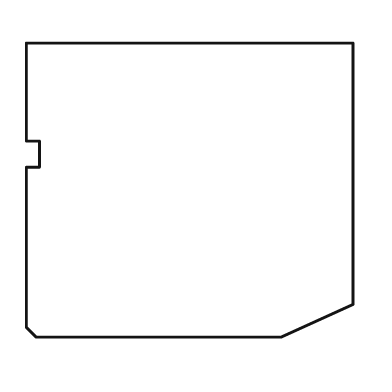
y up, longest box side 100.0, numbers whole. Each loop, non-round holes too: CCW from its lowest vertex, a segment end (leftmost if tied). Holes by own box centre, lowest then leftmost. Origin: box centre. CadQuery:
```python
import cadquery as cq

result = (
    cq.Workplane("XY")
    .moveTo(-47.0, -45.0)
    .lineTo(28.0, -45.0)
    .lineTo(50.0, -35.0)
    .lineTo(50.0, 45.0)
    .lineTo(-50.0, 45.0)
    .lineTo(-50.0, 15.0)
    .lineTo(-46.0, 15.0)
    .lineTo(-46.0, 7.0)
    .lineTo(-50.0, 7.0)
    .lineTo(-50.0, -42.0)
    .close()
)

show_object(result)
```